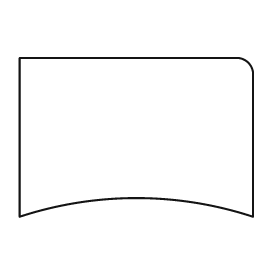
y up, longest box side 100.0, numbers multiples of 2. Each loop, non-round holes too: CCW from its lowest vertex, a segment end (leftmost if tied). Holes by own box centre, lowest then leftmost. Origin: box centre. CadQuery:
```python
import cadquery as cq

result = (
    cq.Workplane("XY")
    .moveTo(-50.0, -34.0)
    .threePointArc((0.0, -26.0), (50.0, -34.0))
    .lineTo(50.0, 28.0)
    .threePointArc((48.0, 32.0), (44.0, 34.0))
    .lineTo(-50.0, 34.0)
    .close()
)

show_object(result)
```